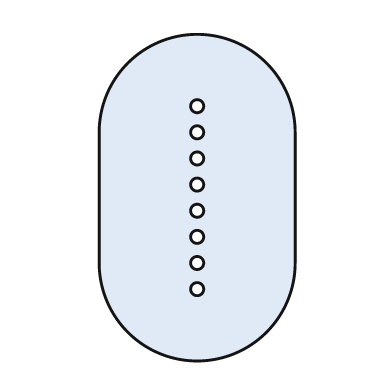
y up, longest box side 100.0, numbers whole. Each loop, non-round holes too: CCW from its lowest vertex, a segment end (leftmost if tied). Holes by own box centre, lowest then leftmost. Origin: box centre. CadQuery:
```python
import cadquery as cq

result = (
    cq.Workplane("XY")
    .moveTo(-30.0, -20.0)
    .threePointArc((0.0, -50.0), (30.0, -20.0))
    .lineTo(30.0, 20.0)
    .threePointArc((0.0, 50.0), (-30.0, 20.0))
    .close()
    .moveTo(0.0, -28.0)
    .circle(2.0)
    .moveTo(0.0, -20.0)
    .circle(2.0)
    .moveTo(0.0, -12.0)
    .circle(2.0)
    .moveTo(0.0, -4.0)
    .circle(2.0)
    .moveTo(0.0, 4.0)
    .circle(2.0)
    .moveTo(0.0, 12.0)
    .circle(2.0)
    .moveTo(0.0, 20.0)
    .circle(2.0)
    .moveTo(0.0, 28.0)
    .circle(2.0)
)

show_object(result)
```